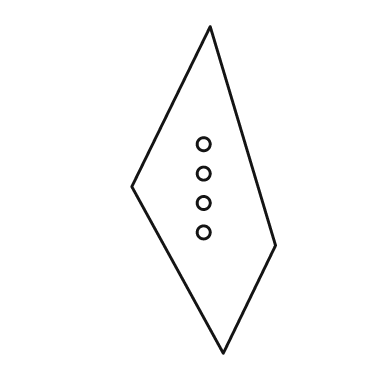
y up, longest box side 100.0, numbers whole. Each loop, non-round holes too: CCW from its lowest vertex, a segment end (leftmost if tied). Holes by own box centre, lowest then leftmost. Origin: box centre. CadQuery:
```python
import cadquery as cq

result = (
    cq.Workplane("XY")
    .moveTo(6.0, -50.0)
    .lineTo(22.0, -17.0)
    .lineTo(2.0, 50.0)
    .lineTo(-22.0, 1.0)
    .close()
    .moveTo(0.0, -13.0)
    .circle(2.0)
    .moveTo(0.0, -4.0)
    .circle(2.0)
    .moveTo(0.0, 5.0)
    .circle(2.0)
    .moveTo(0.0, 14.0)
    .circle(2.0)
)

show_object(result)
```